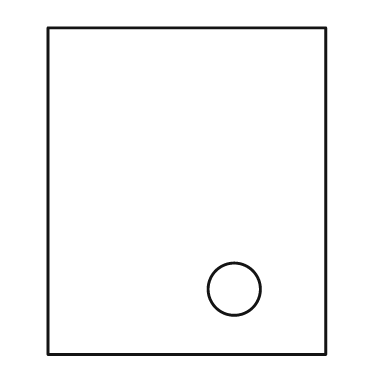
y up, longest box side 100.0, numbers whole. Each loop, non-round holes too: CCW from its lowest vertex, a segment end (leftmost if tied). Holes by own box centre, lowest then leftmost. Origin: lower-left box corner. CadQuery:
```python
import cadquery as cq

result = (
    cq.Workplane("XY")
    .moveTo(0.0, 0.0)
    .lineTo(85.0, 0.0)
    .lineTo(85.0, 100.0)
    .lineTo(0.0, 100.0)
    .close()
    .moveTo(57.0, 20.0)
    .circle(8.0)
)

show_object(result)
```